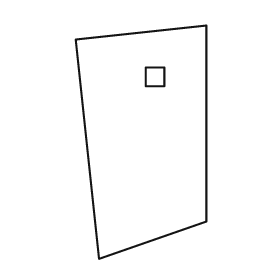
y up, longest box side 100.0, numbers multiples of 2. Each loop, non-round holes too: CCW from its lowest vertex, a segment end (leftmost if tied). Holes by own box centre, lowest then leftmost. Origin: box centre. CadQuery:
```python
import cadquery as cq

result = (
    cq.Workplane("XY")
    .moveTo(-18.0, -50.0)
    .lineTo(28.0, -34.0)
    .lineTo(28.0, 50.0)
    .lineTo(-28.0, 44.0)
    .close()
    .moveTo(2.0, 24.0)
    .lineTo(10.0, 24.0)
    .lineTo(10.0, 32.0)
    .lineTo(2.0, 32.0)
    .close()
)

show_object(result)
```